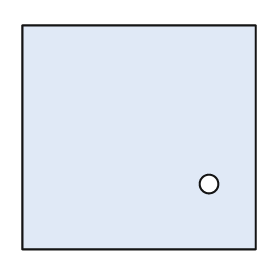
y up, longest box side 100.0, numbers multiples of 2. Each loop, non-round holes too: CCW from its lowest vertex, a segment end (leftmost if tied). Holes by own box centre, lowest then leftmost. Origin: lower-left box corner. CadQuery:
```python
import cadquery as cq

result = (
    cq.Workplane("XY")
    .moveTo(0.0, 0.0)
    .lineTo(100.0, 0.0)
    .lineTo(100.0, 96.0)
    .lineTo(0.0, 96.0)
    .close()
    .moveTo(80.0, 28.0)
    .circle(4.0)
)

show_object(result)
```